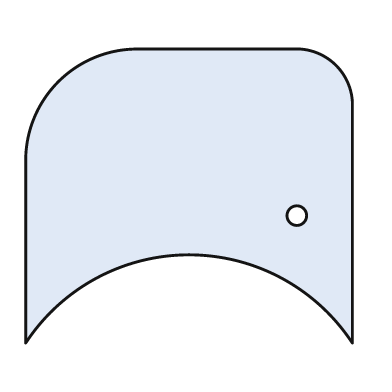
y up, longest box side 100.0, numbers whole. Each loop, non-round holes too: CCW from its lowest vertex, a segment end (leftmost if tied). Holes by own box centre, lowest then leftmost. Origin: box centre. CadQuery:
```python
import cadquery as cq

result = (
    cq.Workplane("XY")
    .moveTo(-50.0, -45.0)
    .threePointArc((0.0, -18.0), (50.0, -45.0))
    .lineTo(50.0, 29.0)
    .threePointArc((45.0, 40.0), (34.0, 45.0))
    .lineTo(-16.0, 45.0)
    .threePointArc((-40.0, 35.0), (-50.0, 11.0))
    .close()
    .moveTo(33.0, -6.0)
    .circle(3.0)
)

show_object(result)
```